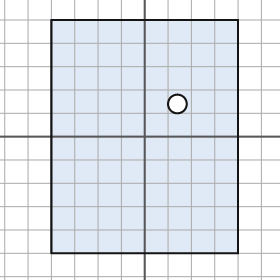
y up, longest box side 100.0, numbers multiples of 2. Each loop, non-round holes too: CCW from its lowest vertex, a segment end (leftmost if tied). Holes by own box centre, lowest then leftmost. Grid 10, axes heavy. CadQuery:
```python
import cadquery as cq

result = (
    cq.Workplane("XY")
    .moveTo(-40.0, -50.0)
    .lineTo(40.0, -50.0)
    .lineTo(40.0, 50.0)
    .lineTo(-40.0, 50.0)
    .close()
    .moveTo(14.0, 14.0)
    .circle(4.0)
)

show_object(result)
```